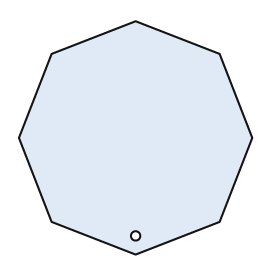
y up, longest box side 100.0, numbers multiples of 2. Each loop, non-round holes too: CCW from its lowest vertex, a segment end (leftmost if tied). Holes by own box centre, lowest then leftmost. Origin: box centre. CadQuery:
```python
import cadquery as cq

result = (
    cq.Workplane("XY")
    .moveTo(0.0, -50.0)
    .lineTo(36.0, -36.0)
    .lineTo(50.0, 0.0)
    .lineTo(36.0, 36.0)
    .lineTo(0.0, 50.0)
    .lineTo(-36.0, 36.0)
    .lineTo(-50.0, 0.0)
    .lineTo(-36.0, -36.0)
    .close()
    .moveTo(0.0, -42.0)
    .circle(2.0)
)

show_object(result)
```